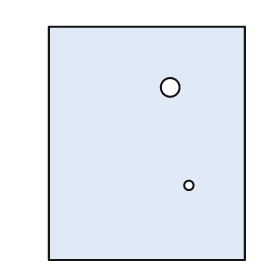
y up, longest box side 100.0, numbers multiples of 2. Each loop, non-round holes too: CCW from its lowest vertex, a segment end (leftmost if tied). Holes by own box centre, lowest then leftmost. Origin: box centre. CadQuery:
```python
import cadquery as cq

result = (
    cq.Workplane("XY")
    .moveTo(-42.0, -50.0)
    .lineTo(42.0, -50.0)
    .lineTo(42.0, 50.0)
    .lineTo(-42.0, 50.0)
    .close()
    .moveTo(18.0, -18.0)
    .circle(2.0)
    .moveTo(10.0, 24.0)
    .circle(4.0)
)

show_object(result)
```